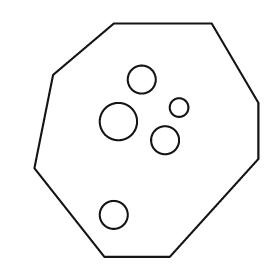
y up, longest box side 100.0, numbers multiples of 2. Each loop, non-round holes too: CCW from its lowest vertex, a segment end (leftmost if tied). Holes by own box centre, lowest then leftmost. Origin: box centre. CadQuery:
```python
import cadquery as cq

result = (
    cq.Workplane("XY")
    .moveTo(-18.0, -50.0)
    .lineTo(10.0, -50.0)
    .lineTo(48.0, -8.0)
    .lineTo(48.0, 16.0)
    .lineTo(28.0, 50.0)
    .lineTo(-14.0, 50.0)
    .lineTo(-40.0, 28.0)
    .lineTo(-48.0, -12.0)
    .close()
    .moveTo(-14.0, -32.0)
    .circle(6.0)
    .moveTo(8.0, 0.0)
    .circle(6.0)
    .moveTo(-12.0, 8.0)
    .circle(8.0)
    .moveTo(14.0, 14.0)
    .circle(4.0)
    .moveTo(-2.0, 26.0)
    .circle(6.0)
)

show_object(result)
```